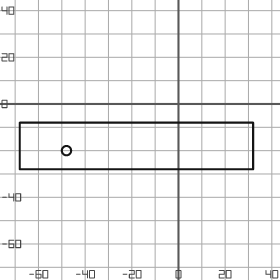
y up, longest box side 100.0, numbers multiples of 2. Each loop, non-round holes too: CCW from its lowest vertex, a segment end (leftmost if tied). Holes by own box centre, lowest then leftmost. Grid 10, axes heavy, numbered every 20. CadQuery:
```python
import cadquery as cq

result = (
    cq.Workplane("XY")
    .moveTo(-68.0, -28.0)
    .lineTo(32.0, -28.0)
    .lineTo(32.0, -8.0)
    .lineTo(-68.0, -8.0)
    .close()
    .moveTo(-48.0, -20.0)
    .circle(2.0)
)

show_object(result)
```